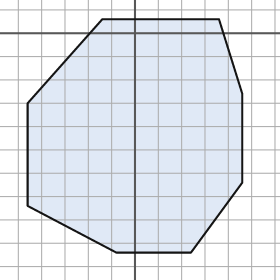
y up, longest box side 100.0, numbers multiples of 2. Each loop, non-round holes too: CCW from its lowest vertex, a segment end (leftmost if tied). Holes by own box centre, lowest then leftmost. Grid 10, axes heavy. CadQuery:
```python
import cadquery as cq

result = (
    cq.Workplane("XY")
    .moveTo(-8.0, -94.0)
    .lineTo(24.0, -94.0)
    .lineTo(46.0, -64.0)
    .lineTo(46.0, -26.0)
    .lineTo(36.0, 6.0)
    .lineTo(-14.0, 6.0)
    .lineTo(-46.0, -30.0)
    .lineTo(-46.0, -74.0)
    .close()
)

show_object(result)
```